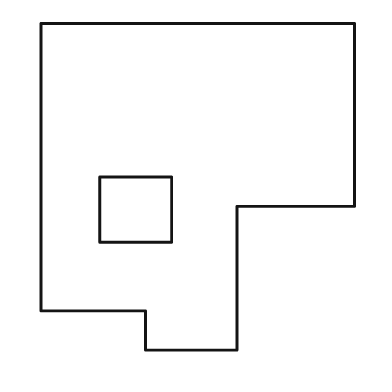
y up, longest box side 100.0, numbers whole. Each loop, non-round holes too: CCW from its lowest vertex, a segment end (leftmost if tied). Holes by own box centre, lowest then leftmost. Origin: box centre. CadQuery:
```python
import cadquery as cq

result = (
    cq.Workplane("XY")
    .moveTo(-16.0, -50.0)
    .lineTo(12.0, -50.0)
    .lineTo(12.0, -6.0)
    .lineTo(48.0, -6.0)
    .lineTo(48.0, 50.0)
    .lineTo(-48.0, 50.0)
    .lineTo(-48.0, -38.0)
    .lineTo(-16.0, -38.0)
    .close()
    .moveTo(-30.0, -17.0)
    .lineTo(-8.0, -17.0)
    .lineTo(-8.0, 3.0)
    .lineTo(-30.0, 3.0)
    .close()
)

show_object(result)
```